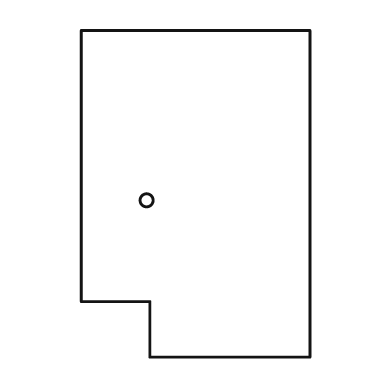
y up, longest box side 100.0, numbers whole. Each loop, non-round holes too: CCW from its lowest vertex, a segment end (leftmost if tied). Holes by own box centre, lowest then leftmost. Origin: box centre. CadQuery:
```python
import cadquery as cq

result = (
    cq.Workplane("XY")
    .moveTo(-14.0, -50.0)
    .lineTo(35.0, -50.0)
    .lineTo(35.0, 50.0)
    .lineTo(-35.0, 50.0)
    .lineTo(-35.0, -33.0)
    .lineTo(-14.0, -33.0)
    .close()
    .moveTo(-15.0, -2.0)
    .circle(2.0)
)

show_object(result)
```